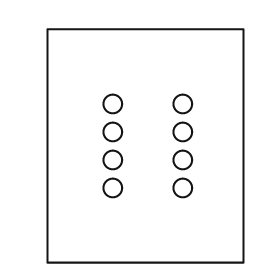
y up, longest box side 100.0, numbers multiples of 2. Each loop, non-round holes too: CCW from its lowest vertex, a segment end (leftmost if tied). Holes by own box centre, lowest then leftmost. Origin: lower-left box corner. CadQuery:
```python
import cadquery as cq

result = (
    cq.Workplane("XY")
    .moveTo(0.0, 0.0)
    .lineTo(84.0, 0.0)
    .lineTo(84.0, 100.0)
    .lineTo(0.0, 100.0)
    .close()
    .moveTo(28.0, 32.0)
    .circle(4.0)
    .moveTo(58.0, 32.0)
    .circle(4.0)
    .moveTo(28.0, 44.0)
    .circle(4.0)
    .moveTo(58.0, 44.0)
    .circle(4.0)
    .moveTo(28.0, 56.0)
    .circle(4.0)
    .moveTo(58.0, 56.0)
    .circle(4.0)
    .moveTo(28.0, 68.0)
    .circle(4.0)
    .moveTo(58.0, 68.0)
    .circle(4.0)
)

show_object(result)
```